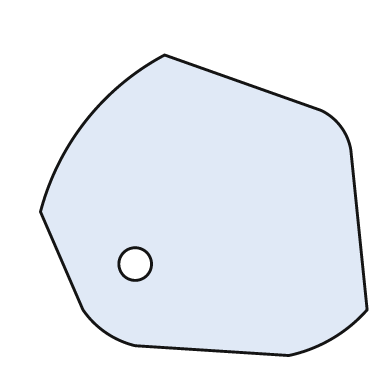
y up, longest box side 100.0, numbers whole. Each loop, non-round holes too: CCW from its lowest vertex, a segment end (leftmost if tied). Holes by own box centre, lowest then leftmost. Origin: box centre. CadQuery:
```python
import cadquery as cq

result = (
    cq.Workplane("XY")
    .moveTo(26.0, -46.0)
    .threePointArc((39.0, -41.0), (50.0, -32.0))
    .lineTo(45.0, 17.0)
    .threePointArc((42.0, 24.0), (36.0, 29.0))
    .lineTo(-12.0, 46.0)
    .threePointArc((-36.0, 26.0), (-50.0, -2.0))
    .lineTo(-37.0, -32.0)
    .threePointArc((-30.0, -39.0), (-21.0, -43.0))
    .close()
    .moveTo(-21.0, -18.0)
    .circle(5.0)
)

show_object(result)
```